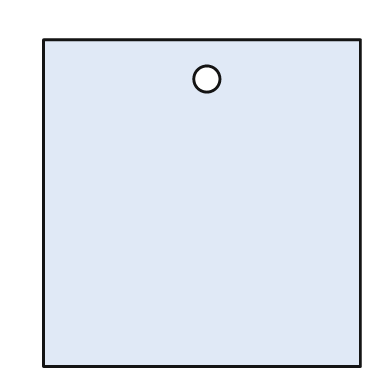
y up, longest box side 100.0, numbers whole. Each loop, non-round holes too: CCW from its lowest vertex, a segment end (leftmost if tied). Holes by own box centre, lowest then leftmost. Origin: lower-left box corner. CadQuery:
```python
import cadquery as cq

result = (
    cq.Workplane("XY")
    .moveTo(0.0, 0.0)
    .lineTo(97.0, 0.0)
    .lineTo(97.0, 100.0)
    .lineTo(0.0, 100.0)
    .close()
    .moveTo(50.0, 88.0)
    .circle(4.0)
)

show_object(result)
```